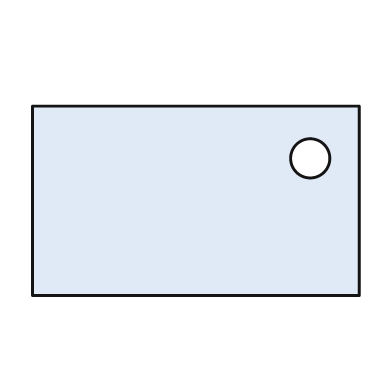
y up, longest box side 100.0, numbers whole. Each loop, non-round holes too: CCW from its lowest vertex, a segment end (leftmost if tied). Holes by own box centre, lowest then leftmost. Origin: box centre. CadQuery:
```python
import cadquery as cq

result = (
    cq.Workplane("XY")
    .moveTo(-50.0, -29.0)
    .lineTo(50.0, -29.0)
    .lineTo(50.0, 29.0)
    .lineTo(-50.0, 29.0)
    .close()
    .moveTo(35.0, 13.0)
    .circle(6.0)
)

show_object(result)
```